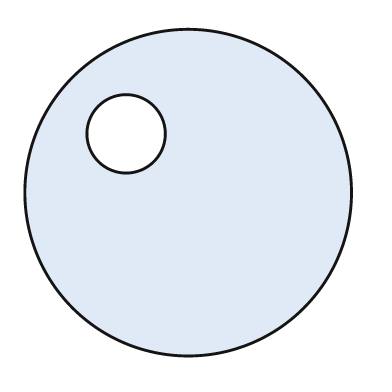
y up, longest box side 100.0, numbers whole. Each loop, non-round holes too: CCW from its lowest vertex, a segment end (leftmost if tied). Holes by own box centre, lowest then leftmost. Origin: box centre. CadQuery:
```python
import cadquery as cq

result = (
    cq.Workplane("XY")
    .moveTo(0.0, 0.0)
    .circle(50.0)
    .moveTo(-19.0, 18.0)
    .circle(12.0)
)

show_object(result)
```